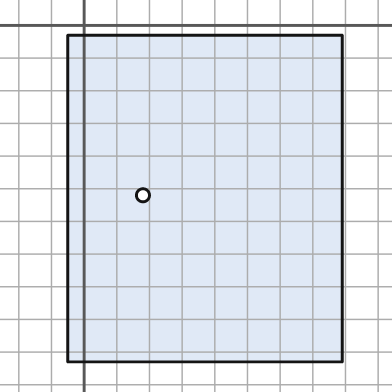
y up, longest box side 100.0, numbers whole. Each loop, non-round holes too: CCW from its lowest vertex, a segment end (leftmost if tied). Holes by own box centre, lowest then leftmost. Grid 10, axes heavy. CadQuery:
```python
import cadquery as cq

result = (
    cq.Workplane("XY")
    .moveTo(-5.0, -103.0)
    .lineTo(79.0, -103.0)
    .lineTo(79.0, -3.0)
    .lineTo(-5.0, -3.0)
    .close()
    .moveTo(18.0, -52.0)
    .circle(2.0)
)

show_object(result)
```